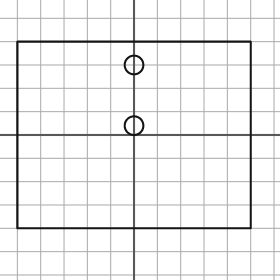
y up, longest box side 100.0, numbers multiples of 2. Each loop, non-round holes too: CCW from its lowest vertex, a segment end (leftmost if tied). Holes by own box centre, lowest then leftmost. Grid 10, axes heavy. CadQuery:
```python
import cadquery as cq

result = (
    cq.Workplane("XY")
    .moveTo(-50.0, -40.0)
    .lineTo(50.0, -40.0)
    .lineTo(50.0, 40.0)
    .lineTo(-50.0, 40.0)
    .close()
    .moveTo(0.0, 4.0)
    .circle(4.0)
    .moveTo(0.0, 30.0)
    .circle(4.0)
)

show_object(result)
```